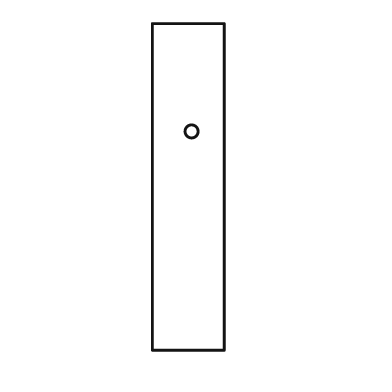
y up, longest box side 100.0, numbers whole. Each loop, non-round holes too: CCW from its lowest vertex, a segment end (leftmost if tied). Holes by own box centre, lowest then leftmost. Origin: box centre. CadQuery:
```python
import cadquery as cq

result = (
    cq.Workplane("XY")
    .moveTo(-11.0, -50.0)
    .lineTo(11.0, -50.0)
    .lineTo(11.0, 50.0)
    .lineTo(-11.0, 50.0)
    .close()
    .moveTo(1.0, 17.0)
    .circle(2.0)
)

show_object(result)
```